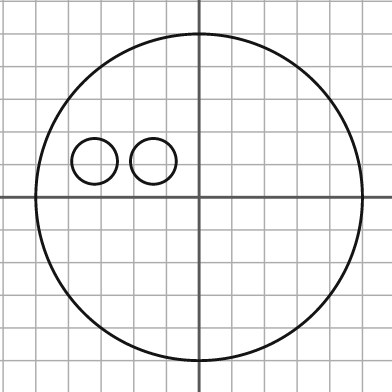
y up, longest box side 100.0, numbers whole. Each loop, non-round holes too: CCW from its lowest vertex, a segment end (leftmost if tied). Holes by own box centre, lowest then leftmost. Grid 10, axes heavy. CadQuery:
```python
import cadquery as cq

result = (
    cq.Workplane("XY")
    .moveTo(0.0, 0.0)
    .circle(50.0)
    .moveTo(-32.0, 11.0)
    .circle(7.0)
    .moveTo(-14.0, 11.0)
    .circle(7.0)
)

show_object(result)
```